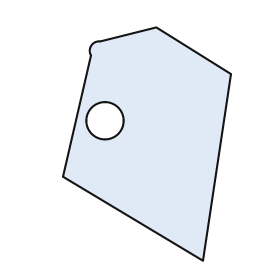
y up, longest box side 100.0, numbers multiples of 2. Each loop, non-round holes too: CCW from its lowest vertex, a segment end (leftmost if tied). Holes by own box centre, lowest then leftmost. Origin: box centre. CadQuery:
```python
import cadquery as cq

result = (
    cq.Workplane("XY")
    .moveTo(24.0, -50.0)
    .lineTo(36.0, 30.0)
    .lineTo(4.0, 50.0)
    .lineTo(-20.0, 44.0)
    .threePointArc((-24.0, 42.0), (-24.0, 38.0))
    .lineTo(-36.0, -14.0)
    .close()
    .moveTo(-18.0, 10.0)
    .circle(8.0)
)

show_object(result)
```